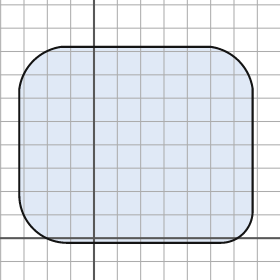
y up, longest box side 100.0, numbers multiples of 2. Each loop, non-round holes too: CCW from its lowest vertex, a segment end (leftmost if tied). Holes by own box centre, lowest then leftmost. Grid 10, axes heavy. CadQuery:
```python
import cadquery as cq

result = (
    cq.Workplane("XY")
    .moveTo(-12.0, -2.0)
    .lineTo(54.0, -2.0)
    .threePointArc((64.0, 2.0), (68.0, 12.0))
    .lineTo(68.0, 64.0)
    .threePointArc((62.0, 76.0), (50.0, 82.0))
    .lineTo(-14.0, 82.0)
    .threePointArc((-26.0, 76.0), (-32.0, 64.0))
    .lineTo(-32.0, 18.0)
    .threePointArc((-26.0, 4.0), (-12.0, -2.0))
    .close()
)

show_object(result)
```